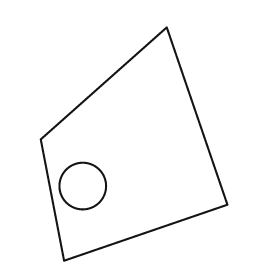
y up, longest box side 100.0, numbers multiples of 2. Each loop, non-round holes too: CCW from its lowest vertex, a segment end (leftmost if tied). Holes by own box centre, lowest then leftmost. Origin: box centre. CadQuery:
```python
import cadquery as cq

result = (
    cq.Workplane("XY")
    .moveTo(-30.0, -50.0)
    .lineTo(40.0, -26.0)
    .lineTo(14.0, 50.0)
    .lineTo(-40.0, 2.0)
    .close()
    .moveTo(-22.0, -18.0)
    .circle(10.0)
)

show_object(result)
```